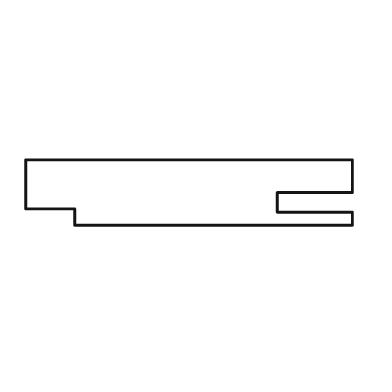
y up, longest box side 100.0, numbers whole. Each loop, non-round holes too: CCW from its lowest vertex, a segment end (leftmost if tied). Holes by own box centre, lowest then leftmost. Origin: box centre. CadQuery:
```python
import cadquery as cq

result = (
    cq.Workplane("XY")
    .moveTo(-35.0, -10.0)
    .lineTo(50.0, -10.0)
    .lineTo(50.0, -6.0)
    .lineTo(27.0, -6.0)
    .lineTo(27.0, 0.0)
    .lineTo(50.0, 0.0)
    .lineTo(50.0, 10.0)
    .lineTo(-50.0, 10.0)
    .lineTo(-50.0, -5.0)
    .lineTo(-35.0, -5.0)
    .close()
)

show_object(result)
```